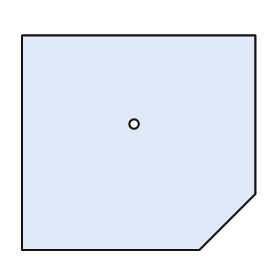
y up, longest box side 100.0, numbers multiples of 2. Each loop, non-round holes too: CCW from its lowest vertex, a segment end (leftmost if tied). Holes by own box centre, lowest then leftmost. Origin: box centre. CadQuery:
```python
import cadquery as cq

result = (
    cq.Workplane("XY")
    .moveTo(-50.0, -46.0)
    .lineTo(26.0, -46.0)
    .lineTo(50.0, -22.0)
    .lineTo(50.0, 46.0)
    .lineTo(-50.0, 46.0)
    .close()
    .moveTo(-2.0, 8.0)
    .circle(2.0)
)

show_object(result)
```